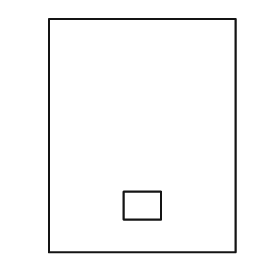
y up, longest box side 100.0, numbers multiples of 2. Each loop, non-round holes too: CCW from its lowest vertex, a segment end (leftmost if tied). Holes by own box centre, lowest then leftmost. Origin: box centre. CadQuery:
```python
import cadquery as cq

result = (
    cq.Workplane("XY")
    .moveTo(-40.0, -50.0)
    .lineTo(40.0, -50.0)
    .lineTo(40.0, 50.0)
    .lineTo(-40.0, 50.0)
    .close()
    .moveTo(-8.0, -36.0)
    .lineTo(8.0, -36.0)
    .lineTo(8.0, -24.0)
    .lineTo(-8.0, -24.0)
    .close()
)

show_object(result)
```